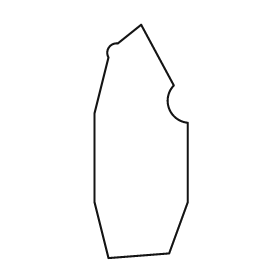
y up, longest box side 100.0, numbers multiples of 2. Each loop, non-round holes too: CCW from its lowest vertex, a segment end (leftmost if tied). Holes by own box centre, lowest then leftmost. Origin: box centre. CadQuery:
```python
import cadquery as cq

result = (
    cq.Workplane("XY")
    .moveTo(-14.0, -50.0)
    .lineTo(12.0, -48.0)
    .lineTo(20.0, -26.0)
    .lineTo(20.0, 8.0)
    .threePointArc((12.0, 14.0), (14.0, 24.0))
    .lineTo(0.0, 50.0)
    .lineTo(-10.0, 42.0)
    .threePointArc((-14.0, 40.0), (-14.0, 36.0))
    .lineTo(-20.0, 12.0)
    .lineTo(-20.0, -26.0)
    .close()
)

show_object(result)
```